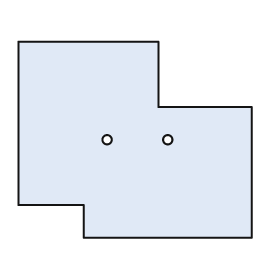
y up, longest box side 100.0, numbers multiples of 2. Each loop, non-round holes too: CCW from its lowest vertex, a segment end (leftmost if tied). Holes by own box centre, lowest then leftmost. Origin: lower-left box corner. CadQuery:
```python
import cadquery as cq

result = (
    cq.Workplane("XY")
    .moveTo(28.0, 0.0)
    .lineTo(100.0, 0.0)
    .lineTo(100.0, 56.0)
    .lineTo(60.0, 56.0)
    .lineTo(60.0, 84.0)
    .lineTo(0.0, 84.0)
    .lineTo(0.0, 14.0)
    .lineTo(28.0, 14.0)
    .close()
    .moveTo(38.0, 42.0)
    .circle(2.0)
    .moveTo(64.0, 42.0)
    .circle(2.0)
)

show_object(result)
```